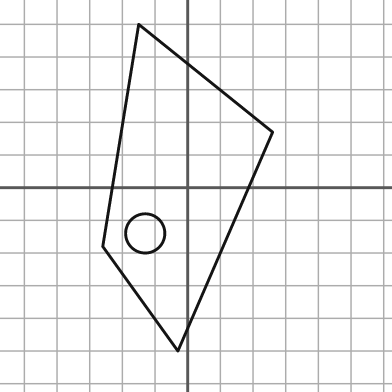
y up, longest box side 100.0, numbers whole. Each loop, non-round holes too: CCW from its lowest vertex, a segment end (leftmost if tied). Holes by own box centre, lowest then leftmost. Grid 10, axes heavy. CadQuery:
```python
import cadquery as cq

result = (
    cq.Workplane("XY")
    .moveTo(-3.0, -50.0)
    .lineTo(26.0, 17.0)
    .lineTo(-15.0, 50.0)
    .lineTo(-26.0, -18.0)
    .close()
    .moveTo(-13.0, -14.0)
    .circle(6.0)
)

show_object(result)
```